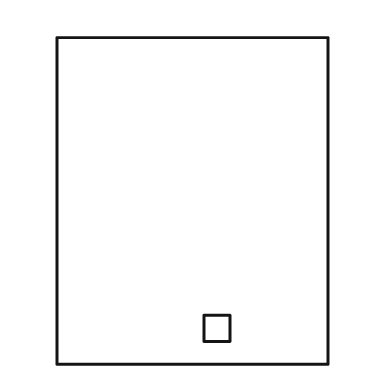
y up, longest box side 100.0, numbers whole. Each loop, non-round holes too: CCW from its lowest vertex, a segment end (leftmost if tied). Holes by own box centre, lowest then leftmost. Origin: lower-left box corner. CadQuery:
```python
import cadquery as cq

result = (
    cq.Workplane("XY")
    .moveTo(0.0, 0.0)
    .lineTo(83.0, 0.0)
    .lineTo(83.0, 100.0)
    .lineTo(0.0, 100.0)
    .close()
    .moveTo(45.0, 7.0)
    .lineTo(53.0, 7.0)
    .lineTo(53.0, 15.0)
    .lineTo(45.0, 15.0)
    .close()
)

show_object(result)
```